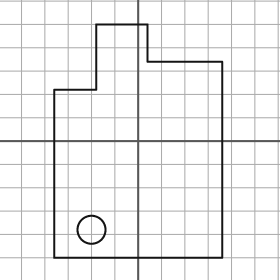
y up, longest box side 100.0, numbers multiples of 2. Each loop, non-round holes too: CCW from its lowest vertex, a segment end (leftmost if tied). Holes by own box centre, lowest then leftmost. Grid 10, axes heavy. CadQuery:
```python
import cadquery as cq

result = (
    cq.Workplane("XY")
    .moveTo(-36.0, -50.0)
    .lineTo(36.0, -50.0)
    .lineTo(36.0, 34.0)
    .lineTo(4.0, 34.0)
    .lineTo(4.0, 50.0)
    .lineTo(-18.0, 50.0)
    .lineTo(-18.0, 22.0)
    .lineTo(-36.0, 22.0)
    .close()
    .moveTo(-20.0, -38.0)
    .circle(6.0)
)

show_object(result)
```